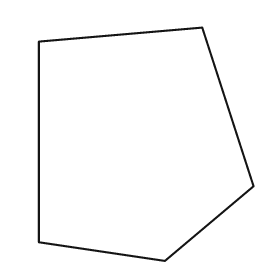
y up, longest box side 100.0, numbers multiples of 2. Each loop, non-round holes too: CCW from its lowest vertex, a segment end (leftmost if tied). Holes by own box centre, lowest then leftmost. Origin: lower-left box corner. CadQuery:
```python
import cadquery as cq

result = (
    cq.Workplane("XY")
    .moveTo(54.0, 0.0)
    .lineTo(92.0, 32.0)
    .lineTo(70.0, 100.0)
    .lineTo(0.0, 94.0)
    .lineTo(0.0, 8.0)
    .close()
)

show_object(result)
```